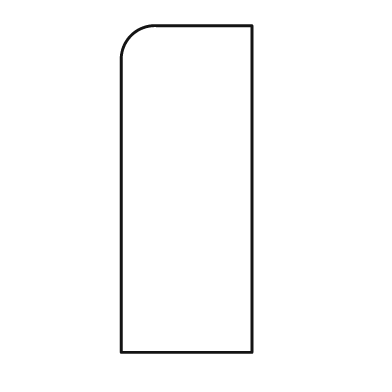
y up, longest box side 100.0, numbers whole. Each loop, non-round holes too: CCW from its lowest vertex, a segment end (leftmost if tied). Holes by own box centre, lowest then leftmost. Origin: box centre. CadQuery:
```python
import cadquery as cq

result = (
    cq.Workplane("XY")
    .moveTo(-20.0, -50.0)
    .lineTo(20.0, -50.0)
    .lineTo(20.0, 50.0)
    .lineTo(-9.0, 50.0)
    .threePointArc((-17.0, 47.0), (-20.0, 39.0))
    .close()
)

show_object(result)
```